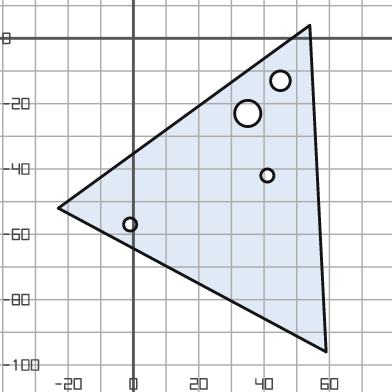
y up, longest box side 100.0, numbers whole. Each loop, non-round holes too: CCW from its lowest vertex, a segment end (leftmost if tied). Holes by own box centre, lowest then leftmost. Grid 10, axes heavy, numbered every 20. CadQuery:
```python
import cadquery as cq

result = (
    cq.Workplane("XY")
    .moveTo(59.0, -96.0)
    .lineTo(54.0, 4.0)
    .lineTo(-23.0, -52.0)
    .close()
    .moveTo(-1.0, -57.0)
    .circle(2.0)
    .moveTo(41.0, -42.0)
    .circle(2.0)
    .moveTo(35.0, -23.0)
    .circle(4.0)
    .moveTo(45.0, -13.0)
    .circle(3.0)
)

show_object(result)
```